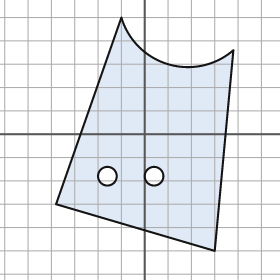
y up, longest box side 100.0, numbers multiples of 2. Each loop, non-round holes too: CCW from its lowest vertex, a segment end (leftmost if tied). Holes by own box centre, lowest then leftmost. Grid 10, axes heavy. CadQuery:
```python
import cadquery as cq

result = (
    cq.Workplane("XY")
    .moveTo(30.0, -50.0)
    .lineTo(38.0, 36.0)
    .threePointArc((10.0, 30.0), (-10.0, 50.0))
    .lineTo(-38.0, -30.0)
    .close()
    .moveTo(-16.0, -18.0)
    .circle(4.0)
    .moveTo(4.0, -18.0)
    .circle(4.0)
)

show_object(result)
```